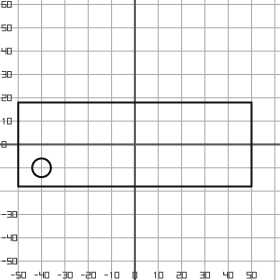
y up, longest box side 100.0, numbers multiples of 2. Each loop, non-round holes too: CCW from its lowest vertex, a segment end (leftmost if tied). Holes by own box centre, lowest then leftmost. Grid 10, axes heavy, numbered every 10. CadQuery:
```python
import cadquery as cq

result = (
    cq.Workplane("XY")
    .moveTo(-50.0, -18.0)
    .lineTo(50.0, -18.0)
    .lineTo(50.0, 18.0)
    .lineTo(-50.0, 18.0)
    .close()
    .moveTo(-40.0, -10.0)
    .circle(4.0)
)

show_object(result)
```